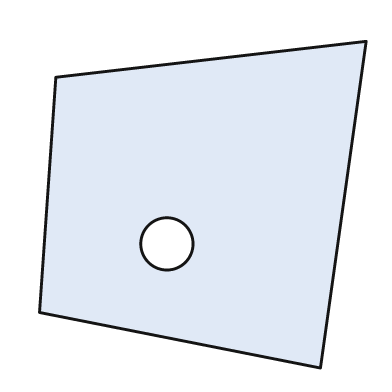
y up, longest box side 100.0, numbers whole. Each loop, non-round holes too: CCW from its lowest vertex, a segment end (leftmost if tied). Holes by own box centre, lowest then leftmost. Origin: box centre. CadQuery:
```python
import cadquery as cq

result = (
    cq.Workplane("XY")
    .moveTo(36.0, -50.0)
    .lineTo(50.0, 50.0)
    .lineTo(-45.0, 39.0)
    .lineTo(-50.0, -33.0)
    .close()
    .moveTo(-11.0, -12.0)
    .circle(8.0)
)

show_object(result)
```